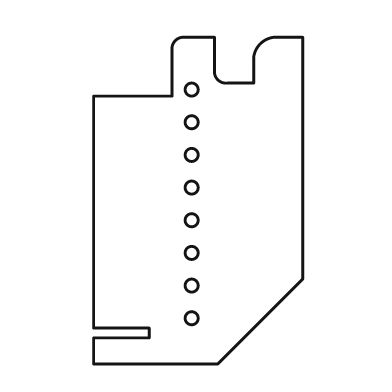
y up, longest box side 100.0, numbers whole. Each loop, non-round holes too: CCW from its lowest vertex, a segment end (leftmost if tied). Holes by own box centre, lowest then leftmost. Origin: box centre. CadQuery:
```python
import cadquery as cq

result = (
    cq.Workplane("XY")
    .moveTo(-32.0, -50.0)
    .lineTo(6.0, -50.0)
    .lineTo(32.0, -24.0)
    .lineTo(32.0, 50.0)
    .lineTo(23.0, 50.0)
    .threePointArc((19.0, 48.0), (17.0, 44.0))
    .lineTo(17.0, 36.0)
    .lineTo(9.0, 36.0)
    .threePointArc((6.0, 37.0), (5.0, 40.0))
    .lineTo(5.0, 50.0)
    .lineTo(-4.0, 50.0)
    .threePointArc((-7.0, 49.0), (-8.0, 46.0))
    .lineTo(-8.0, 32.0)
    .lineTo(-32.0, 32.0)
    .lineTo(-32.0, -39.0)
    .lineTo(-15.0, -39.0)
    .lineTo(-15.0, -42.0)
    .lineTo(-32.0, -42.0)
    .close()
    .moveTo(-2.0, -36.0)
    .circle(2.0)
    .moveTo(-2.0, -26.0)
    .circle(2.0)
    .moveTo(-2.0, -16.0)
    .circle(2.0)
    .moveTo(-2.0, -6.0)
    .circle(2.0)
    .moveTo(-2.0, 4.0)
    .circle(2.0)
    .moveTo(-2.0, 14.0)
    .circle(2.0)
    .moveTo(-2.0, 24.0)
    .circle(2.0)
    .moveTo(-2.0, 34.0)
    .circle(2.0)
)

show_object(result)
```